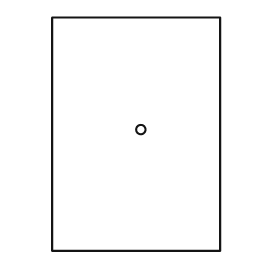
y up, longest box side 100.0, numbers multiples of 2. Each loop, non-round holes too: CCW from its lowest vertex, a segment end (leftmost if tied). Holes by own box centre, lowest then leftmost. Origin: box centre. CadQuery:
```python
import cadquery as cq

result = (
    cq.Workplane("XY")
    .moveTo(-36.0, -50.0)
    .lineTo(36.0, -50.0)
    .lineTo(36.0, 50.0)
    .lineTo(-36.0, 50.0)
    .close()
    .moveTo(2.0, 2.0)
    .circle(2.0)
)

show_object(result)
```